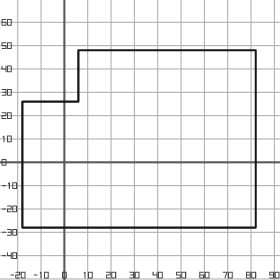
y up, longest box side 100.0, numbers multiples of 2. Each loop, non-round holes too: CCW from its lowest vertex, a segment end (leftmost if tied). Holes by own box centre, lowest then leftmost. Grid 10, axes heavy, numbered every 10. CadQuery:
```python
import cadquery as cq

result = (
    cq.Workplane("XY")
    .moveTo(-18.0, -28.0)
    .lineTo(82.0, -28.0)
    .lineTo(82.0, 48.0)
    .lineTo(6.0, 48.0)
    .lineTo(6.0, 26.0)
    .lineTo(-18.0, 26.0)
    .close()
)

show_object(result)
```